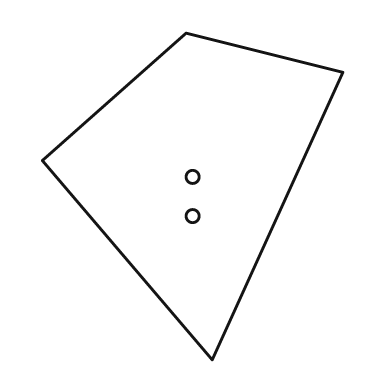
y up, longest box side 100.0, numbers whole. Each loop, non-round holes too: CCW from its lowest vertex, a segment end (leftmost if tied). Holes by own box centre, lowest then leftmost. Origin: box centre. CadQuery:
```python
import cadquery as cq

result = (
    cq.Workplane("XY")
    .moveTo(6.0, -50.0)
    .lineTo(46.0, 38.0)
    .lineTo(-2.0, 50.0)
    .lineTo(-46.0, 11.0)
    .close()
    .moveTo(0.0, -6.0)
    .circle(2.0)
    .moveTo(0.0, 6.0)
    .circle(2.0)
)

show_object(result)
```